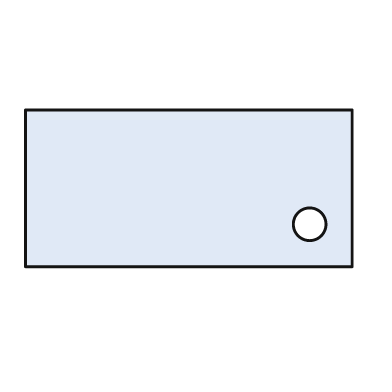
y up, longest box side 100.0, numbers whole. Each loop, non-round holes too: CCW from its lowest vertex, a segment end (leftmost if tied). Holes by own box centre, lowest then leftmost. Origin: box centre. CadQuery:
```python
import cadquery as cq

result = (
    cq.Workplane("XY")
    .moveTo(-50.0, -24.0)
    .lineTo(50.0, -24.0)
    .lineTo(50.0, 24.0)
    .lineTo(-50.0, 24.0)
    .close()
    .moveTo(37.0, -11.0)
    .circle(5.0)
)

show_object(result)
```